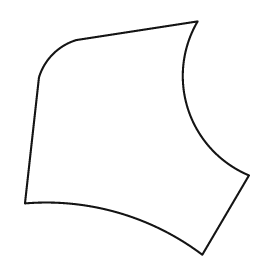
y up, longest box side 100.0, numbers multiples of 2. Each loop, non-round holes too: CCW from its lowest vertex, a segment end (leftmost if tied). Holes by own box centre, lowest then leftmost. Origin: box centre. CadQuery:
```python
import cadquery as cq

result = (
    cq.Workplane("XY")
    .moveTo(28.0, -50.0)
    .lineTo(48.0, -16.0)
    .threePointArc((22.0, 12.0), (26.0, 50.0))
    .lineTo(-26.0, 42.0)
    .threePointArc((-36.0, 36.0), (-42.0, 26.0))
    .lineTo(-48.0, -28.0)
    .threePointArc((-8.0, -32.0), (28.0, -50.0))
    .close()
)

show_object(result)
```